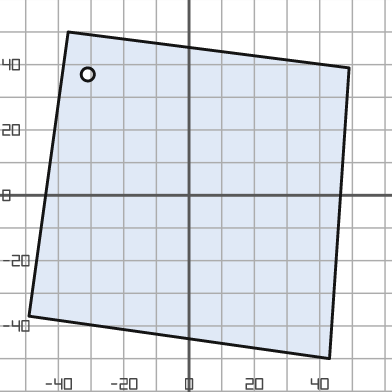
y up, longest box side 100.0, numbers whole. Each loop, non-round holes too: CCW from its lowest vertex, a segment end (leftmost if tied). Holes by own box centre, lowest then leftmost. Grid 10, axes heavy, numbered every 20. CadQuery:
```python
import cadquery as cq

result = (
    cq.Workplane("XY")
    .moveTo(43.0, -50.0)
    .lineTo(49.0, 39.0)
    .lineTo(-37.0, 50.0)
    .lineTo(-49.0, -37.0)
    .close()
    .moveTo(-31.0, 37.0)
    .circle(2.0)
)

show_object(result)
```